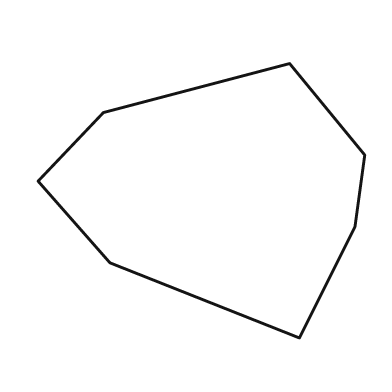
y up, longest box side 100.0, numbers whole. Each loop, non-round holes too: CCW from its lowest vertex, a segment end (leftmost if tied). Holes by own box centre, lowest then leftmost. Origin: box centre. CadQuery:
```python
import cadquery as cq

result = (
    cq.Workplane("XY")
    .moveTo(30.0, -42.0)
    .lineTo(47.0, -8.0)
    .lineTo(50.0, 14.0)
    .lineTo(27.0, 42.0)
    .lineTo(-30.0, 27.0)
    .lineTo(-50.0, 6.0)
    .lineTo(-28.0, -19.0)
    .close()
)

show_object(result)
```